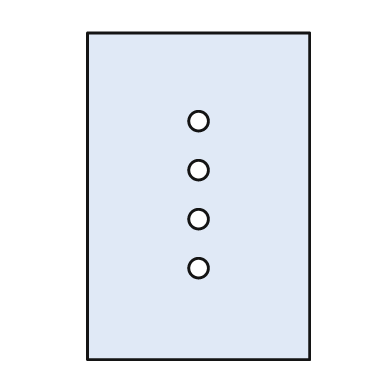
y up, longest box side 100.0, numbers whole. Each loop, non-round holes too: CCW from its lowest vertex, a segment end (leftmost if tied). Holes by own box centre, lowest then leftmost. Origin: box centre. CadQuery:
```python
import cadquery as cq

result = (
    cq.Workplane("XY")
    .moveTo(-34.0, -50.0)
    .lineTo(34.0, -50.0)
    .lineTo(34.0, 50.0)
    .lineTo(-34.0, 50.0)
    .close()
    .moveTo(0.0, -22.0)
    .circle(3.0)
    .moveTo(0.0, -7.0)
    .circle(3.0)
    .moveTo(0.0, 8.0)
    .circle(3.0)
    .moveTo(0.0, 23.0)
    .circle(3.0)
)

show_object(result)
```